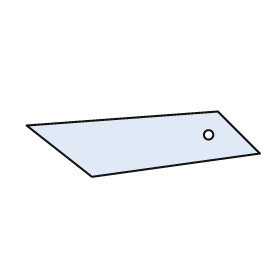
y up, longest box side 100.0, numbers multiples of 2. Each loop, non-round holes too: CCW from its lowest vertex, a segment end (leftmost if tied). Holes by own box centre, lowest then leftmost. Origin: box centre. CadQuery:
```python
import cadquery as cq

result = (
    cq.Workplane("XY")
    .moveTo(-22.0, -14.0)
    .lineTo(50.0, -4.0)
    .lineTo(32.0, 14.0)
    .lineTo(-50.0, 8.0)
    .close()
    .moveTo(28.0, 4.0)
    .circle(2.0)
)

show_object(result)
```